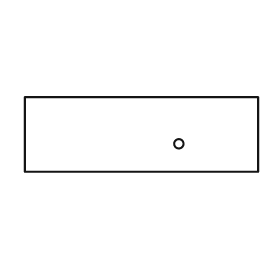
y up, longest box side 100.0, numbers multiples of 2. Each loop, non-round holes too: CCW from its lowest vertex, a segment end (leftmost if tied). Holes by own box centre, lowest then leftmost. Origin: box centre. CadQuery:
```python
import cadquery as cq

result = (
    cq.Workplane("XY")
    .moveTo(-50.0, -16.0)
    .lineTo(50.0, -16.0)
    .lineTo(50.0, 16.0)
    .lineTo(-50.0, 16.0)
    .close()
    .moveTo(16.0, -4.0)
    .circle(2.0)
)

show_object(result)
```